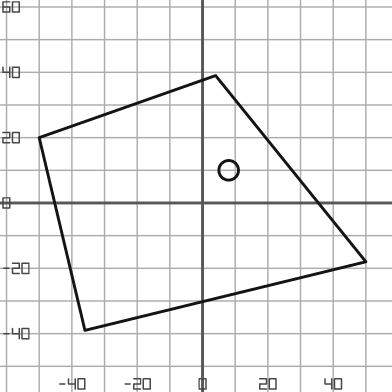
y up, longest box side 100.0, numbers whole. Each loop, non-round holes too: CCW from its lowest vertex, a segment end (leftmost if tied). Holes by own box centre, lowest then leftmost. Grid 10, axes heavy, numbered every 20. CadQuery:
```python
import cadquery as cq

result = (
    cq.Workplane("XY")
    .moveTo(-36.0, -39.0)
    .lineTo(50.0, -18.0)
    .lineTo(4.0, 39.0)
    .lineTo(-50.0, 20.0)
    .close()
    .moveTo(8.0, 10.0)
    .circle(3.0)
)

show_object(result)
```